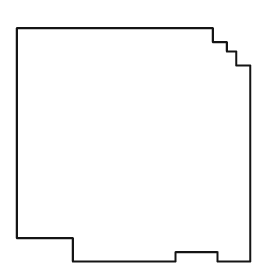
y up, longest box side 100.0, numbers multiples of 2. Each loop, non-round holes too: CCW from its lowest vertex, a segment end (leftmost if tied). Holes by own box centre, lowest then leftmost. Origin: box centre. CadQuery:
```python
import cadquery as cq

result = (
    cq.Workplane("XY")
    .moveTo(-26.0, -50.0)
    .lineTo(18.0, -50.0)
    .lineTo(18.0, -46.0)
    .lineTo(36.0, -46.0)
    .lineTo(36.0, -50.0)
    .lineTo(50.0, -50.0)
    .lineTo(50.0, 34.0)
    .lineTo(44.0, 34.0)
    .lineTo(44.0, 40.0)
    .lineTo(40.0, 40.0)
    .lineTo(40.0, 44.0)
    .lineTo(34.0, 44.0)
    .lineTo(34.0, 50.0)
    .lineTo(-50.0, 50.0)
    .lineTo(-50.0, -40.0)
    .lineTo(-26.0, -40.0)
    .close()
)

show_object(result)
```